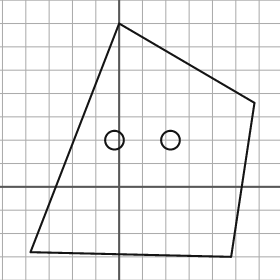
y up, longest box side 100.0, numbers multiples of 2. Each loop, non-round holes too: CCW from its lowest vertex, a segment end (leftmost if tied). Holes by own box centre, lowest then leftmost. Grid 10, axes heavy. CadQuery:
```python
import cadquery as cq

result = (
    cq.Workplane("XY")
    .moveTo(48.0, -30.0)
    .lineTo(58.0, 36.0)
    .lineTo(0.0, 70.0)
    .lineTo(-38.0, -28.0)
    .close()
    .moveTo(-2.0, 20.0)
    .circle(4.0)
    .moveTo(22.0, 20.0)
    .circle(4.0)
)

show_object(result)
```